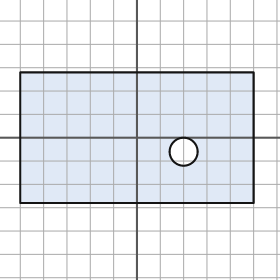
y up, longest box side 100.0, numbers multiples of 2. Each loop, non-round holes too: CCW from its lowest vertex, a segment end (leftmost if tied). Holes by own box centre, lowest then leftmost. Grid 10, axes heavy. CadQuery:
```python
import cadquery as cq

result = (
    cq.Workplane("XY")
    .moveTo(-50.0, -28.0)
    .lineTo(50.0, -28.0)
    .lineTo(50.0, 28.0)
    .lineTo(-50.0, 28.0)
    .close()
    .moveTo(20.0, -6.0)
    .circle(6.0)
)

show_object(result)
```